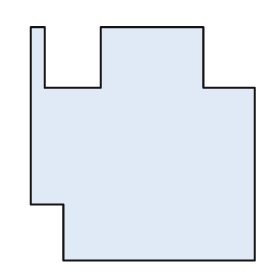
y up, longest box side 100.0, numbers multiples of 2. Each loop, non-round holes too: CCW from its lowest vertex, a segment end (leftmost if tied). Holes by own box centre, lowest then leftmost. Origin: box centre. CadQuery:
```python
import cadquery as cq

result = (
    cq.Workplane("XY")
    .moveTo(-34.0, -50.0)
    .lineTo(48.0, -50.0)
    .lineTo(48.0, 24.0)
    .lineTo(26.0, 24.0)
    .lineTo(26.0, 50.0)
    .lineTo(-18.0, 50.0)
    .lineTo(-18.0, 24.0)
    .lineTo(-42.0, 24.0)
    .lineTo(-42.0, 50.0)
    .lineTo(-48.0, 50.0)
    .lineTo(-48.0, -26.0)
    .lineTo(-34.0, -26.0)
    .close()
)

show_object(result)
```